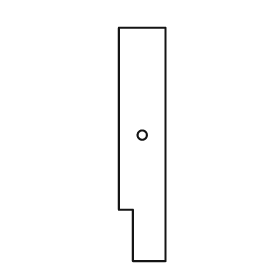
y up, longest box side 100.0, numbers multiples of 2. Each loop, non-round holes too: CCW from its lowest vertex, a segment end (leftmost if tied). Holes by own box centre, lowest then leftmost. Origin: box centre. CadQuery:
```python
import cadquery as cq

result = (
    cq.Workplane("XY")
    .moveTo(-4.0, -50.0)
    .lineTo(10.0, -50.0)
    .lineTo(10.0, 50.0)
    .lineTo(-10.0, 50.0)
    .lineTo(-10.0, -28.0)
    .lineTo(-4.0, -28.0)
    .close()
    .moveTo(0.0, 4.0)
    .circle(2.0)
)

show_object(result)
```